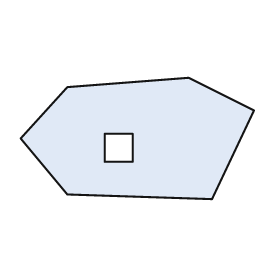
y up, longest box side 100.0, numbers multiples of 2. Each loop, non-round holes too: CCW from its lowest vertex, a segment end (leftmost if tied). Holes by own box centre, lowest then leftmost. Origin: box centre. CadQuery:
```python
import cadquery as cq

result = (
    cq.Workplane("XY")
    .moveTo(32.0, -26.0)
    .lineTo(50.0, 12.0)
    .lineTo(22.0, 26.0)
    .lineTo(-30.0, 22.0)
    .lineTo(-50.0, 0.0)
    .lineTo(-30.0, -24.0)
    .close()
    .moveTo(-14.0, -10.0)
    .lineTo(-2.0, -10.0)
    .lineTo(-2.0, 2.0)
    .lineTo(-14.0, 2.0)
    .close()
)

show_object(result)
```